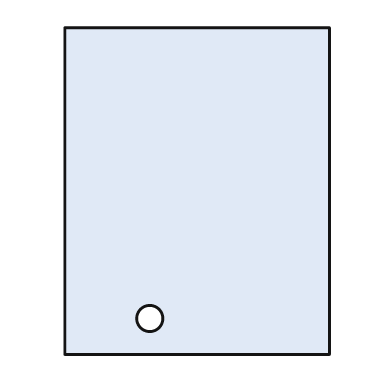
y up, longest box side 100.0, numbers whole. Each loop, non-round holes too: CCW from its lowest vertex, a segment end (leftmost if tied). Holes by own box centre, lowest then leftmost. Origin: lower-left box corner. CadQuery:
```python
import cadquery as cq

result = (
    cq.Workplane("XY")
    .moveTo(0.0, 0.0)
    .lineTo(81.0, 0.0)
    .lineTo(81.0, 100.0)
    .lineTo(0.0, 100.0)
    .close()
    .moveTo(26.0, 11.0)
    .circle(4.0)
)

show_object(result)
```